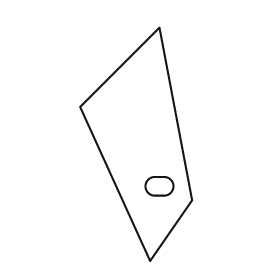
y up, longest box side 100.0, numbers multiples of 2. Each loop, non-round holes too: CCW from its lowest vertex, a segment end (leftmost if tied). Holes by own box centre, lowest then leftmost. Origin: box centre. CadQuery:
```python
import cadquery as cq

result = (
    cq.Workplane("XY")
    .moveTo(6.0, -50.0)
    .lineTo(24.0, -24.0)
    .lineTo(10.0, 50.0)
    .lineTo(-24.0, 16.0)
    .close()
    .moveTo(8.0, -22.0)
    .lineTo(12.0, -22.0)
    .threePointArc((16.0, -18.0), (12.0, -14.0))
    .lineTo(8.0, -14.0)
    .threePointArc((4.0, -18.0), (8.0, -22.0))
    .close()
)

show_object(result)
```